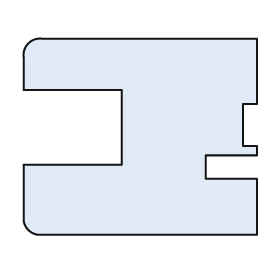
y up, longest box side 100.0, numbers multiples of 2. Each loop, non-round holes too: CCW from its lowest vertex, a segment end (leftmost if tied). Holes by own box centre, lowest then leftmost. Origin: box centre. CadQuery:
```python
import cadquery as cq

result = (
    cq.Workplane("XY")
    .moveTo(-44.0, -42.0)
    .lineTo(50.0, -42.0)
    .lineTo(50.0, -18.0)
    .lineTo(28.0, -18.0)
    .lineTo(28.0, -8.0)
    .lineTo(50.0, -8.0)
    .lineTo(50.0, -4.0)
    .lineTo(44.0, -4.0)
    .lineTo(44.0, 14.0)
    .lineTo(50.0, 14.0)
    .lineTo(50.0, 42.0)
    .lineTo(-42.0, 42.0)
    .threePointArc((-48.0, 40.0), (-50.0, 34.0))
    .lineTo(-50.0, 20.0)
    .lineTo(-8.0, 20.0)
    .lineTo(-8.0, -12.0)
    .lineTo(-50.0, -12.0)
    .lineTo(-50.0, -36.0)
    .threePointArc((-48.0, -40.0), (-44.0, -42.0))
    .close()
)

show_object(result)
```